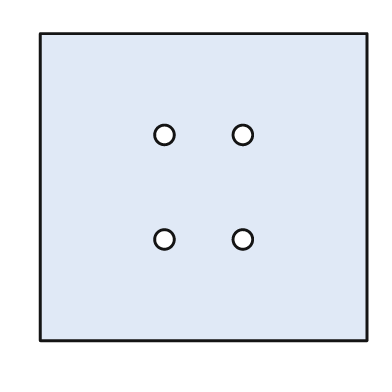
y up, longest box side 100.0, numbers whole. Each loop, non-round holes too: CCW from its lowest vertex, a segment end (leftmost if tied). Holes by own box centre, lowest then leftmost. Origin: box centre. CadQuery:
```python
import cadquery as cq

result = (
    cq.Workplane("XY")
    .moveTo(-50.0, -47.0)
    .lineTo(50.0, -47.0)
    .lineTo(50.0, 47.0)
    .lineTo(-50.0, 47.0)
    .close()
    .moveTo(-12.0, -16.0)
    .circle(3.0)
    .moveTo(12.0, -16.0)
    .circle(3.0)
    .moveTo(-12.0, 16.0)
    .circle(3.0)
    .moveTo(12.0, 16.0)
    .circle(3.0)
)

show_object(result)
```